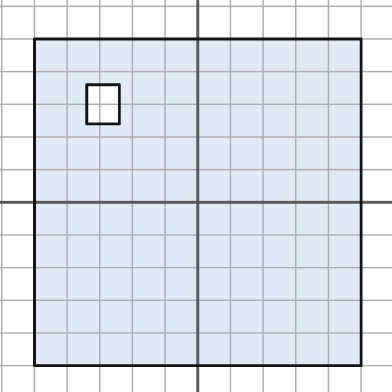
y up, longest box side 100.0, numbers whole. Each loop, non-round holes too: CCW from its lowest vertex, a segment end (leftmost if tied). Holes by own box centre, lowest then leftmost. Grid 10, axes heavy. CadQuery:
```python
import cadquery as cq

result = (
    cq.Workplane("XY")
    .moveTo(-50.0, -50.0)
    .lineTo(50.0, -50.0)
    .lineTo(50.0, 50.0)
    .lineTo(-50.0, 50.0)
    .close()
    .moveTo(-34.0, 24.0)
    .lineTo(-24.0, 24.0)
    .lineTo(-24.0, 36.0)
    .lineTo(-34.0, 36.0)
    .close()
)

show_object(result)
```